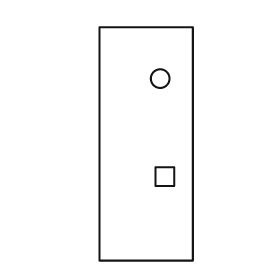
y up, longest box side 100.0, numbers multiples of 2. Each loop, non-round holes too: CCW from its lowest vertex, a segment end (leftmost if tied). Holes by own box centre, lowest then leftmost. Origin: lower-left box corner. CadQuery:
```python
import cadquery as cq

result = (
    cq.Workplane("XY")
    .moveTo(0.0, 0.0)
    .lineTo(40.0, 0.0)
    .lineTo(40.0, 100.0)
    .lineTo(0.0, 100.0)
    .close()
    .moveTo(24.0, 32.0)
    .lineTo(32.0, 32.0)
    .lineTo(32.0, 40.0)
    .lineTo(24.0, 40.0)
    .close()
    .moveTo(26.0, 78.0)
    .circle(4.0)
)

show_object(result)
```